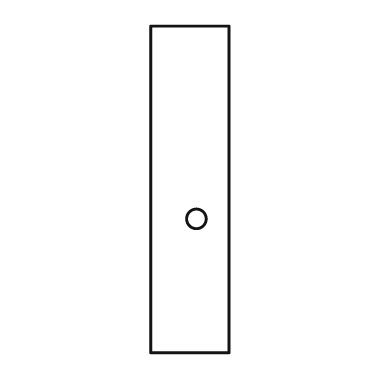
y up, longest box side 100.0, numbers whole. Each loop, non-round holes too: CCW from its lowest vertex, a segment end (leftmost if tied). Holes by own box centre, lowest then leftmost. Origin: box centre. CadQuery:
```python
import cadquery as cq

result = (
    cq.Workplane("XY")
    .moveTo(-12.0, -50.0)
    .lineTo(12.0, -50.0)
    .lineTo(12.0, 50.0)
    .lineTo(-12.0, 50.0)
    .close()
    .moveTo(2.0, -9.0)
    .circle(3.0)
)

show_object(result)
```